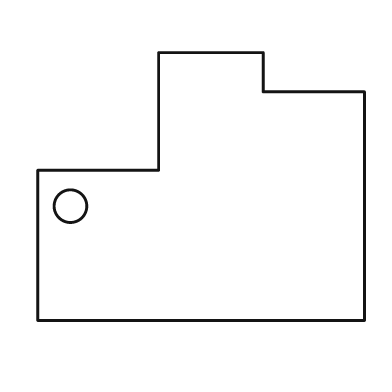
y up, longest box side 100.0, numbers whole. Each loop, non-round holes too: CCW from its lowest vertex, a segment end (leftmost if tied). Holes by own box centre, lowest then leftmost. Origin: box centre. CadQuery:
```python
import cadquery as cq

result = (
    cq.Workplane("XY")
    .moveTo(-50.0, -41.0)
    .lineTo(50.0, -41.0)
    .lineTo(50.0, 29.0)
    .lineTo(19.0, 29.0)
    .lineTo(19.0, 41.0)
    .lineTo(-13.0, 41.0)
    .lineTo(-13.0, 5.0)
    .lineTo(-50.0, 5.0)
    .close()
    .moveTo(-40.0, -6.0)
    .circle(5.0)
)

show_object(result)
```